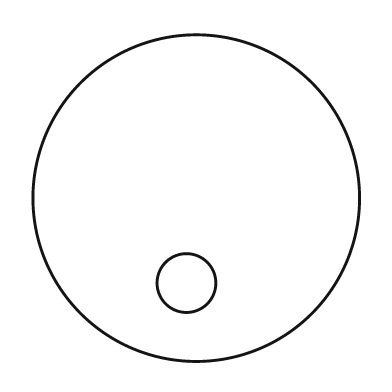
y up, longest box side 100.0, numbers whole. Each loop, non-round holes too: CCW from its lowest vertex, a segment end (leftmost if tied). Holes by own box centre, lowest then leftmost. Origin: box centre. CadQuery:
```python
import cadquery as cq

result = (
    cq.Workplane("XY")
    .moveTo(0.0, 0.0)
    .circle(50.0)
    .moveTo(-3.0, -26.0)
    .circle(9.0)
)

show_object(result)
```